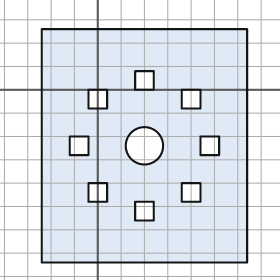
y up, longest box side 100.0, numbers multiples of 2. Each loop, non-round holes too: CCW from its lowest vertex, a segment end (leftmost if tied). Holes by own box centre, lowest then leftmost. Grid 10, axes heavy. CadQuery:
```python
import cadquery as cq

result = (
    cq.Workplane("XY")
    .moveTo(-24.0, -74.0)
    .lineTo(64.0, -74.0)
    .lineTo(64.0, 26.0)
    .lineTo(-24.0, 26.0)
    .close()
    .moveTo(16.0, -56.0)
    .lineTo(24.0, -56.0)
    .lineTo(24.0, -48.0)
    .lineTo(16.0, -48.0)
    .close()
    .moveTo(-4.0, -48.0)
    .lineTo(4.0, -48.0)
    .lineTo(4.0, -40.0)
    .lineTo(-4.0, -40.0)
    .close()
    .moveTo(36.0, -48.0)
    .lineTo(44.0, -48.0)
    .lineTo(44.0, -40.0)
    .lineTo(36.0, -40.0)
    .close()
    .moveTo(-12.0, -28.0)
    .lineTo(-4.0, -28.0)
    .lineTo(-4.0, -20.0)
    .lineTo(-12.0, -20.0)
    .close()
    .moveTo(20.0, -24.0)
    .circle(8.0)
    .moveTo(44.0, -28.0)
    .lineTo(52.0, -28.0)
    .lineTo(52.0, -20.0)
    .lineTo(44.0, -20.0)
    .close()
    .moveTo(-4.0, -8.0)
    .lineTo(4.0, -8.0)
    .lineTo(4.0, 0.0)
    .lineTo(-4.0, 0.0)
    .close()
    .moveTo(36.0, -8.0)
    .lineTo(44.0, -8.0)
    .lineTo(44.0, 0.0)
    .lineTo(36.0, 0.0)
    .close()
    .moveTo(16.0, 0.0)
    .lineTo(24.0, 0.0)
    .lineTo(24.0, 8.0)
    .lineTo(16.0, 8.0)
    .close()
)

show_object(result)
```